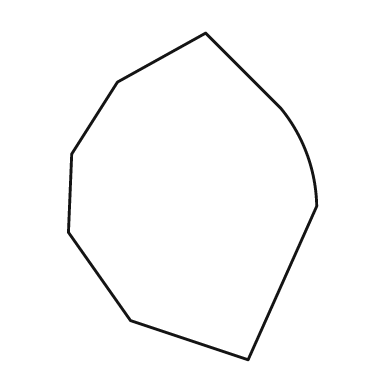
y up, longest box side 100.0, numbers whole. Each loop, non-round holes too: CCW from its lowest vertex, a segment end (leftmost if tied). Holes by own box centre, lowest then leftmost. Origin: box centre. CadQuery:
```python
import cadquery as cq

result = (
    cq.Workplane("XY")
    .moveTo(17.0, -50.0)
    .lineTo(38.0, -3.0)
    .threePointArc((35.0, 13.0), (27.0, 27.0))
    .lineTo(4.0, 50.0)
    .lineTo(-23.0, 35.0)
    .lineTo(-37.0, 13.0)
    .lineTo(-38.0, -11.0)
    .lineTo(-19.0, -38.0)
    .close()
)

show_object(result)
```